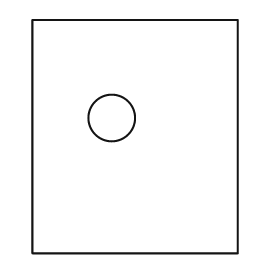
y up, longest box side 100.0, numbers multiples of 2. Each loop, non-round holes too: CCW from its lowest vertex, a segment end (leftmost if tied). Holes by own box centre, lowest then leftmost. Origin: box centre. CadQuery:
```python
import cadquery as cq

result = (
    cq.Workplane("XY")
    .moveTo(-44.0, -50.0)
    .lineTo(44.0, -50.0)
    .lineTo(44.0, 50.0)
    .lineTo(-44.0, 50.0)
    .close()
    .moveTo(-10.0, 8.0)
    .circle(10.0)
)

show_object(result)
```